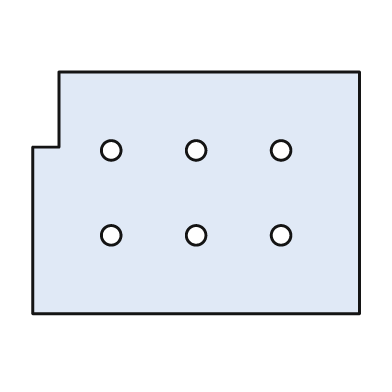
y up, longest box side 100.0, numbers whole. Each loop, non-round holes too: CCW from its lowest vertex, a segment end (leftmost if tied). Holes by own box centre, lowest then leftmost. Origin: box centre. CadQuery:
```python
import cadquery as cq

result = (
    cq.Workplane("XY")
    .moveTo(-50.0, -37.0)
    .lineTo(50.0, -37.0)
    .lineTo(50.0, 37.0)
    .lineTo(-42.0, 37.0)
    .lineTo(-42.0, 14.0)
    .lineTo(-50.0, 14.0)
    .close()
    .moveTo(-26.0, -13.0)
    .circle(3.0)
    .moveTo(0.0, -13.0)
    .circle(3.0)
    .moveTo(26.0, -13.0)
    .circle(3.0)
    .moveTo(-26.0, 13.0)
    .circle(3.0)
    .moveTo(0.0, 13.0)
    .circle(3.0)
    .moveTo(26.0, 13.0)
    .circle(3.0)
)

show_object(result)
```